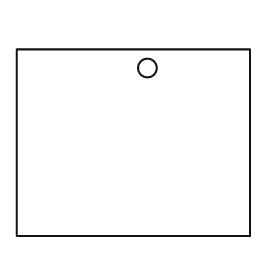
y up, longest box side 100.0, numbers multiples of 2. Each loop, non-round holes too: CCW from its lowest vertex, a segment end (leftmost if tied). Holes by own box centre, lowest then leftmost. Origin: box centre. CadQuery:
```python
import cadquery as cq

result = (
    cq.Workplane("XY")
    .moveTo(-50.0, -40.0)
    .lineTo(50.0, -40.0)
    .lineTo(50.0, 40.0)
    .lineTo(-50.0, 40.0)
    .close()
    .moveTo(6.0, 32.0)
    .circle(4.0)
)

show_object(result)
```